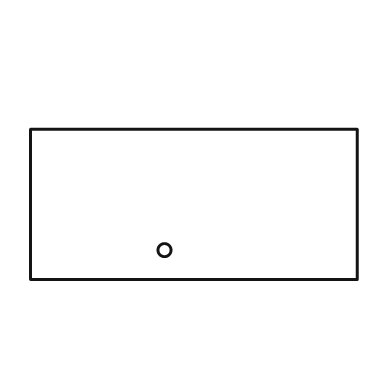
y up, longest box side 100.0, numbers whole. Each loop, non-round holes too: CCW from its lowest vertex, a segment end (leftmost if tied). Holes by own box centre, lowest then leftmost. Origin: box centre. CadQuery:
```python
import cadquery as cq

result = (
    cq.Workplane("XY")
    .moveTo(-50.0, -23.0)
    .lineTo(50.0, -23.0)
    .lineTo(50.0, 23.0)
    .lineTo(-50.0, 23.0)
    .close()
    .moveTo(-9.0, -14.0)
    .circle(2.0)
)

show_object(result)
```